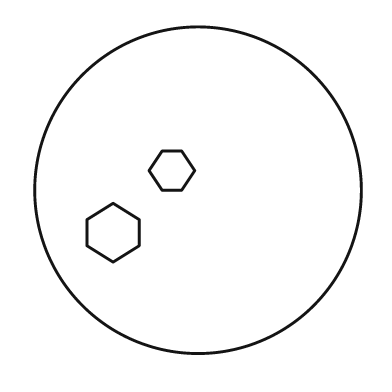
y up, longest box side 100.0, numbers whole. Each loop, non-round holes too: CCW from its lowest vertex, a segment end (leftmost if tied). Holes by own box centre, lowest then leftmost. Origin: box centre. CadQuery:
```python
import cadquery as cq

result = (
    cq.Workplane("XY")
    .moveTo(0.0, 0.0)
    .circle(50.0)
    .moveTo(-26.0, -22.0)
    .lineTo(-18.0, -17.0)
    .lineTo(-18.0, -9.0)
    .lineTo(-26.0, -4.0)
    .lineTo(-34.0, -9.0)
    .lineTo(-34.0, -17.0)
    .close()
    .moveTo(-11.0, 0.0)
    .lineTo(-5.0, 0.0)
    .lineTo(-1.0, 6.0)
    .lineTo(-5.0, 12.0)
    .lineTo(-11.0, 12.0)
    .lineTo(-15.0, 6.0)
    .close()
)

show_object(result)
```